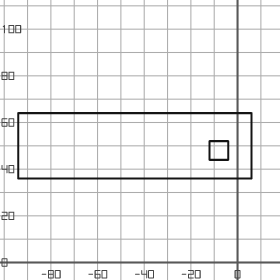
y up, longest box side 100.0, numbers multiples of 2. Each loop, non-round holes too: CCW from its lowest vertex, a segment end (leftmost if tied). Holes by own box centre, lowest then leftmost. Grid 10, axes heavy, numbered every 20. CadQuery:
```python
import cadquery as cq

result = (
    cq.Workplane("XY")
    .moveTo(-94.0, 36.0)
    .lineTo(6.0, 36.0)
    .lineTo(6.0, 64.0)
    .lineTo(-94.0, 64.0)
    .close()
    .moveTo(-12.0, 44.0)
    .lineTo(-4.0, 44.0)
    .lineTo(-4.0, 52.0)
    .lineTo(-12.0, 52.0)
    .close()
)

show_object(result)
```